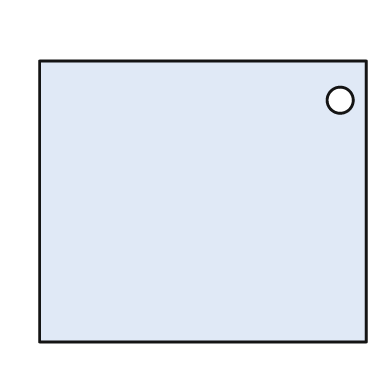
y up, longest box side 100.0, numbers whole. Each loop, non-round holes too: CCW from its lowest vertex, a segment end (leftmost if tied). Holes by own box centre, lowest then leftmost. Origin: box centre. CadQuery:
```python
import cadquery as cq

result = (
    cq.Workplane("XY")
    .moveTo(-50.0, -43.0)
    .lineTo(50.0, -43.0)
    .lineTo(50.0, 43.0)
    .lineTo(-50.0, 43.0)
    .close()
    .moveTo(42.0, 31.0)
    .circle(4.0)
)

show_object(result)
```